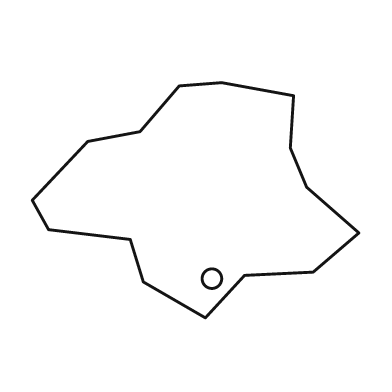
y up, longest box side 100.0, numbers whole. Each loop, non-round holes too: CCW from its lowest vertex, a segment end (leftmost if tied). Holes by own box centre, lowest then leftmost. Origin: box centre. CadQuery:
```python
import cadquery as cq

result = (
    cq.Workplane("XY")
    .moveTo(3.0, -36.0)
    .lineTo(15.0, -23.0)
    .lineTo(36.0, -22.0)
    .lineTo(50.0, -10.0)
    .lineTo(34.0, 4.0)
    .lineTo(29.0, 16.0)
    .lineTo(30.0, 32.0)
    .lineTo(8.0, 36.0)
    .lineTo(-5.0, 35.0)
    .lineTo(-17.0, 21.0)
    .lineTo(-33.0, 18.0)
    .lineTo(-50.0, 0.0)
    .lineTo(-45.0, -9.0)
    .lineTo(-20.0, -12.0)
    .lineTo(-16.0, -25.0)
    .close()
    .moveTo(5.0, -24.0)
    .circle(3.0)
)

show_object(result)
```